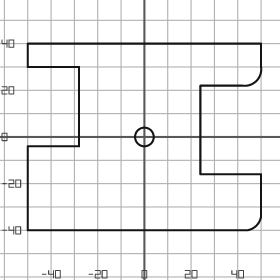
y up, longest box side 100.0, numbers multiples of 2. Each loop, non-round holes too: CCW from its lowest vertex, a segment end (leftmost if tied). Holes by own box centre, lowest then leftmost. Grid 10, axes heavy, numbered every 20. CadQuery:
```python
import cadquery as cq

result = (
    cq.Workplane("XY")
    .moveTo(-50.0, -40.0)
    .lineTo(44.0, -40.0)
    .threePointArc((48.0, -38.0), (50.0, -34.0))
    .lineTo(50.0, -16.0)
    .lineTo(24.0, -16.0)
    .lineTo(24.0, 22.0)
    .lineTo(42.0, 22.0)
    .threePointArc((48.0, 24.0), (50.0, 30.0))
    .lineTo(50.0, 40.0)
    .lineTo(-50.0, 40.0)
    .lineTo(-50.0, 30.0)
    .lineTo(-28.0, 30.0)
    .lineTo(-28.0, -4.0)
    .lineTo(-50.0, -4.0)
    .close()
    .moveTo(0.0, 0.0)
    .circle(4.0)
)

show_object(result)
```